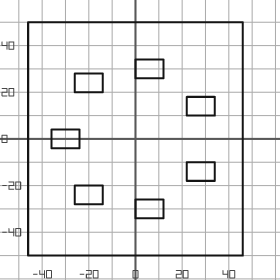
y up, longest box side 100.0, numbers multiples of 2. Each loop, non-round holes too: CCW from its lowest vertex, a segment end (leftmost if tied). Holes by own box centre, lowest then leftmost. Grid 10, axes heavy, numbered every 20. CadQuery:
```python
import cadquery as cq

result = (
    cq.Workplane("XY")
    .moveTo(-46.0, -50.0)
    .lineTo(46.0, -50.0)
    .lineTo(46.0, 50.0)
    .lineTo(-46.0, 50.0)
    .close()
    .moveTo(0.0, -34.0)
    .lineTo(12.0, -34.0)
    .lineTo(12.0, -26.0)
    .lineTo(0.0, -26.0)
    .close()
    .moveTo(-26.0, -28.0)
    .lineTo(-14.0, -28.0)
    .lineTo(-14.0, -20.0)
    .lineTo(-26.0, -20.0)
    .close()
    .moveTo(22.0, -18.0)
    .lineTo(34.0, -18.0)
    .lineTo(34.0, -10.0)
    .lineTo(22.0, -10.0)
    .close()
    .moveTo(-36.0, -4.0)
    .lineTo(-24.0, -4.0)
    .lineTo(-24.0, 4.0)
    .lineTo(-36.0, 4.0)
    .close()
    .moveTo(22.0, 10.0)
    .lineTo(34.0, 10.0)
    .lineTo(34.0, 18.0)
    .lineTo(22.0, 18.0)
    .close()
    .moveTo(-26.0, 20.0)
    .lineTo(-14.0, 20.0)
    .lineTo(-14.0, 28.0)
    .lineTo(-26.0, 28.0)
    .close()
    .moveTo(0.0, 26.0)
    .lineTo(12.0, 26.0)
    .lineTo(12.0, 34.0)
    .lineTo(0.0, 34.0)
    .close()
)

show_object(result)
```